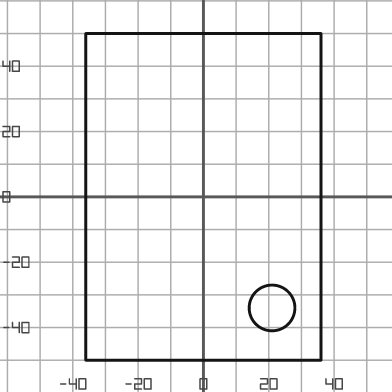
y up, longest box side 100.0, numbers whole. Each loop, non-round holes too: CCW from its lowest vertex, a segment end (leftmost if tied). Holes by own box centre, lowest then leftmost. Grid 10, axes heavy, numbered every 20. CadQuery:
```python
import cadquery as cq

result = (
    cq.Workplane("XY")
    .moveTo(-36.0, -50.0)
    .lineTo(36.0, -50.0)
    .lineTo(36.0, 50.0)
    .lineTo(-36.0, 50.0)
    .close()
    .moveTo(21.0, -34.0)
    .circle(7.0)
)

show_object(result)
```